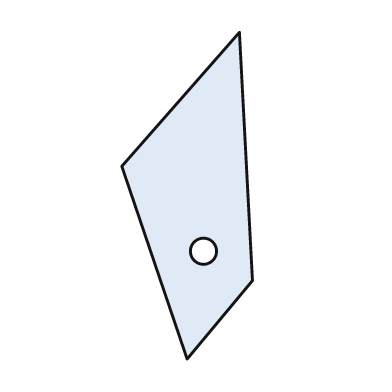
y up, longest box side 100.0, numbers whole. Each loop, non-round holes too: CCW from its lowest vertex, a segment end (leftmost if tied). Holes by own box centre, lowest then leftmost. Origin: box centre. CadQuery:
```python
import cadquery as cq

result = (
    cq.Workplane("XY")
    .moveTo(0.0, -50.0)
    .lineTo(20.0, -26.0)
    .lineTo(16.0, 50.0)
    .lineTo(-20.0, 9.0)
    .close()
    .moveTo(5.0, -17.0)
    .circle(4.0)
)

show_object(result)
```